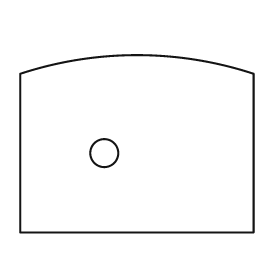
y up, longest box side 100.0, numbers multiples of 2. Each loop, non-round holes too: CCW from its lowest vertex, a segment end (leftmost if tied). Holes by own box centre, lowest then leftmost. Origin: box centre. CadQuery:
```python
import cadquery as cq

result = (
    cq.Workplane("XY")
    .moveTo(-50.0, -38.0)
    .lineTo(50.0, -38.0)
    .lineTo(50.0, 30.0)
    .threePointArc((0.0, 38.0), (-50.0, 30.0))
    .close()
    .moveTo(-14.0, -4.0)
    .circle(6.0)
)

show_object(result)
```